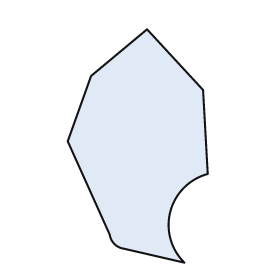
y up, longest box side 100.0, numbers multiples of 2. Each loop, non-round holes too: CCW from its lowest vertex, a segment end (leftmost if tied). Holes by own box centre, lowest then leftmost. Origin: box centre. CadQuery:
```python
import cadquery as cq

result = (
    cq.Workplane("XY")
    .moveTo(20.0, -50.0)
    .threePointArc((14.0, -28.0), (30.0, -12.0))
    .lineTo(28.0, 24.0)
    .lineTo(4.0, 50.0)
    .lineTo(-20.0, 30.0)
    .lineTo(-30.0, 2.0)
    .lineTo(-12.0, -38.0)
    .threePointArc((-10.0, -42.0), (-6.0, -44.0))
    .close()
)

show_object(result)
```